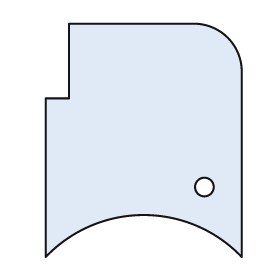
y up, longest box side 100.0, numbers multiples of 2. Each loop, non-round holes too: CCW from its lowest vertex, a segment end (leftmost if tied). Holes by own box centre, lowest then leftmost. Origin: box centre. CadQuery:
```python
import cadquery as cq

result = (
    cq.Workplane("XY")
    .moveTo(-42.0, -50.0)
    .threePointArc((0.0, -32.0), (42.0, -50.0))
    .lineTo(42.0, 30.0)
    .threePointArc((36.0, 44.0), (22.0, 50.0))
    .lineTo(-32.0, 50.0)
    .lineTo(-32.0, 18.0)
    .lineTo(-42.0, 18.0)
    .close()
    .moveTo(26.0, -20.0)
    .circle(4.0)
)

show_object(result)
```